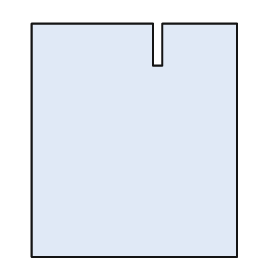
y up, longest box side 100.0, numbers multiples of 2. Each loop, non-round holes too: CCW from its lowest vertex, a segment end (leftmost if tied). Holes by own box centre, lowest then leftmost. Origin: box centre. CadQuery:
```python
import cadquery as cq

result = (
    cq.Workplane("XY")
    .moveTo(-44.0, -50.0)
    .lineTo(44.0, -50.0)
    .lineTo(44.0, 50.0)
    .lineTo(12.0, 50.0)
    .lineTo(12.0, 32.0)
    .lineTo(8.0, 32.0)
    .lineTo(8.0, 50.0)
    .lineTo(-44.0, 50.0)
    .close()
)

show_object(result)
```